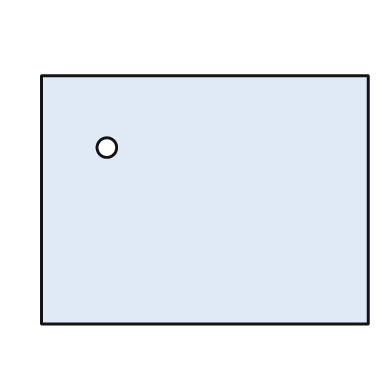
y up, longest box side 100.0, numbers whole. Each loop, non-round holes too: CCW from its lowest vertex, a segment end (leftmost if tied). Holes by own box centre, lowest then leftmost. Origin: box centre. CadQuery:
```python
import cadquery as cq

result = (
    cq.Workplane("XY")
    .moveTo(-50.0, -38.0)
    .lineTo(50.0, -38.0)
    .lineTo(50.0, 38.0)
    .lineTo(-50.0, 38.0)
    .close()
    .moveTo(-30.0, 16.0)
    .circle(3.0)
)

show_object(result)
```